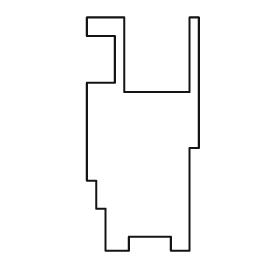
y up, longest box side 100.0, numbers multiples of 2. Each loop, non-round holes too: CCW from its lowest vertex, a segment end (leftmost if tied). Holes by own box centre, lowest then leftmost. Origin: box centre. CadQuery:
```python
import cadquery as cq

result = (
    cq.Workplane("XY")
    .moveTo(-16.0, -50.0)
    .lineTo(-6.0, -50.0)
    .lineTo(-6.0, -44.0)
    .lineTo(12.0, -44.0)
    .lineTo(12.0, -50.0)
    .lineTo(20.0, -50.0)
    .lineTo(20.0, -6.0)
    .lineTo(24.0, -6.0)
    .lineTo(24.0, 50.0)
    .lineTo(20.0, 50.0)
    .lineTo(20.0, 18.0)
    .lineTo(-8.0, 18.0)
    .lineTo(-8.0, 50.0)
    .lineTo(-24.0, 50.0)
    .lineTo(-24.0, 42.0)
    .lineTo(-12.0, 42.0)
    .lineTo(-12.0, 22.0)
    .lineTo(-24.0, 22.0)
    .lineTo(-24.0, -20.0)
    .lineTo(-20.0, -20.0)
    .lineTo(-20.0, -32.0)
    .lineTo(-16.0, -32.0)
    .close()
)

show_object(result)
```